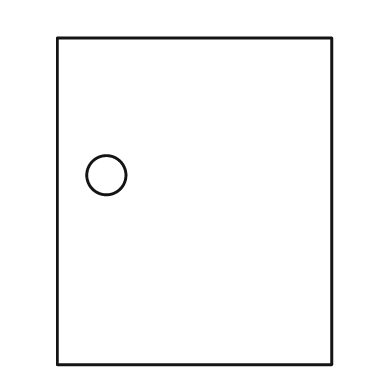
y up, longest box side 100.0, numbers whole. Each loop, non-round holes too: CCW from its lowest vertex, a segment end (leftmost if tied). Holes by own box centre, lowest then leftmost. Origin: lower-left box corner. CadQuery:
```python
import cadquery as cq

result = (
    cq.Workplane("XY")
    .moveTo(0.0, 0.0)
    .lineTo(84.0, 0.0)
    .lineTo(84.0, 100.0)
    .lineTo(0.0, 100.0)
    .close()
    .moveTo(15.0, 58.0)
    .circle(6.0)
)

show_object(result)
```